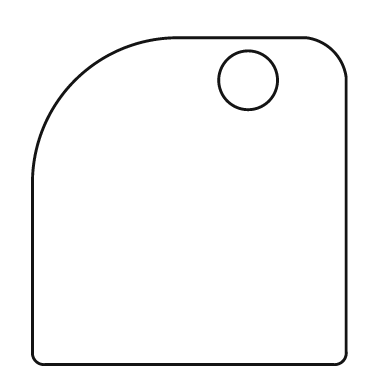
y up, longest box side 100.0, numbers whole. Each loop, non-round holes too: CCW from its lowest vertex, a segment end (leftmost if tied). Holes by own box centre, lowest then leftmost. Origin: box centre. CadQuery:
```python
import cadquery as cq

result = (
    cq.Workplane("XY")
    .moveTo(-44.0, -50.0)
    .lineTo(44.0, -50.0)
    .threePointArc((47.0, -49.0), (48.0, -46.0))
    .lineTo(48.0, 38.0)
    .threePointArc((44.0, 46.0), (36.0, 50.0))
    .lineTo(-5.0, 50.0)
    .threePointArc((-35.0, 37.0), (-48.0, 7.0))
    .lineTo(-48.0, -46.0)
    .threePointArc((-47.0, -49.0), (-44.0, -50.0))
    .close()
    .moveTo(18.0, 37.0)
    .circle(9.0)
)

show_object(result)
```